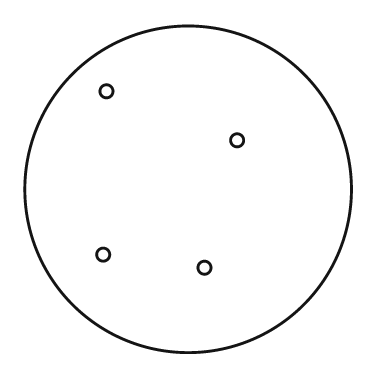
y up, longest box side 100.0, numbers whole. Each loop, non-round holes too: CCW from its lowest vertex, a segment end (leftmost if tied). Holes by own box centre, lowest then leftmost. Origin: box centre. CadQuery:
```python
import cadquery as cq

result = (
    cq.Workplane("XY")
    .moveTo(0.0, 0.0)
    .circle(50.0)
    .moveTo(5.0, -24.0)
    .circle(2.0)
    .moveTo(-26.0, -20.0)
    .circle(2.0)
    .moveTo(15.0, 15.0)
    .circle(2.0)
    .moveTo(-25.0, 30.0)
    .circle(2.0)
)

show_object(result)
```